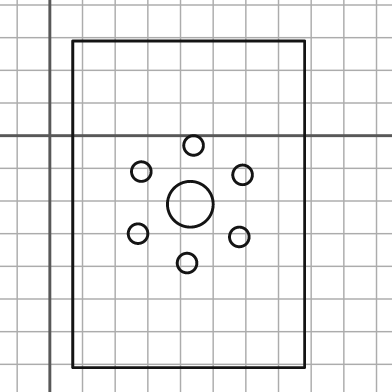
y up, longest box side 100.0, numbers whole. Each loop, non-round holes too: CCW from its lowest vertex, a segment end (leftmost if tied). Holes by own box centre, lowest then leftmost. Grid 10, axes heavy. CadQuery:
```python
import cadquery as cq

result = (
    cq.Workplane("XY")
    .moveTo(7.0, -71.0)
    .lineTo(78.0, -71.0)
    .lineTo(78.0, 29.0)
    .lineTo(7.0, 29.0)
    .close()
    .moveTo(42.0, -39.0)
    .circle(3.0)
    .moveTo(58.0, -31.0)
    .circle(3.0)
    .moveTo(27.0, -30.0)
    .circle(3.0)
    .moveTo(43.0, -21.0)
    .circle(7.0)
    .moveTo(59.0, -12.0)
    .circle(3.0)
    .moveTo(28.0, -11.0)
    .circle(3.0)
    .moveTo(44.0, -3.0)
    .circle(3.0)
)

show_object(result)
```